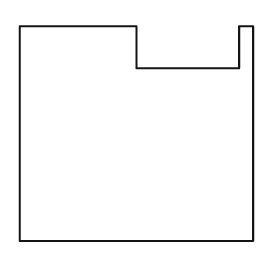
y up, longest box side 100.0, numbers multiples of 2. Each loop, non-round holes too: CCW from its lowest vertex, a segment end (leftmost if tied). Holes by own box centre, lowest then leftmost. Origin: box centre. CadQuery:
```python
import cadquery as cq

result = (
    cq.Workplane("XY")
    .moveTo(-50.0, -46.0)
    .lineTo(50.0, -46.0)
    .lineTo(50.0, 46.0)
    .lineTo(44.0, 46.0)
    .lineTo(44.0, 28.0)
    .lineTo(0.0, 28.0)
    .lineTo(0.0, 46.0)
    .lineTo(-50.0, 46.0)
    .close()
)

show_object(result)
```